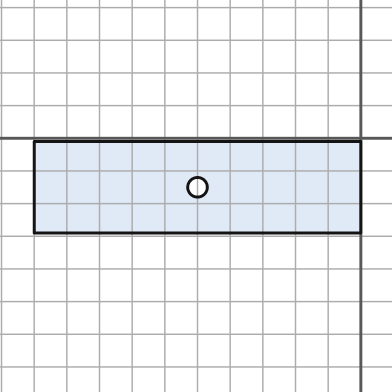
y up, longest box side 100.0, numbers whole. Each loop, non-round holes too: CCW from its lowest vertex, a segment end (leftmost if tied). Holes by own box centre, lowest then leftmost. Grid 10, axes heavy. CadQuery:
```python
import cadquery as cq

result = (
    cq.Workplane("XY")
    .moveTo(-100.0, -29.0)
    .lineTo(0.0, -29.0)
    .lineTo(0.0, -1.0)
    .lineTo(-100.0, -1.0)
    .close()
    .moveTo(-50.0, -15.0)
    .circle(3.0)
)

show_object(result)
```